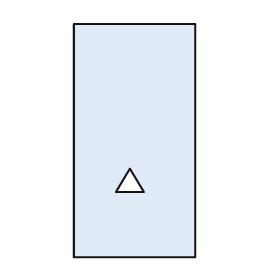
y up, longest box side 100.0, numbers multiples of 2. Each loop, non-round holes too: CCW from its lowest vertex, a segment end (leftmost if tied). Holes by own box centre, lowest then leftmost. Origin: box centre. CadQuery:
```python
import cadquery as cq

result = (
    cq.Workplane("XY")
    .moveTo(-26.0, -50.0)
    .lineTo(26.0, -50.0)
    .lineTo(26.0, 50.0)
    .lineTo(-26.0, 50.0)
    .close()
    .moveTo(-8.0, -22.0)
    .lineTo(4.0, -22.0)
    .lineTo(-2.0, -12.0)
    .close()
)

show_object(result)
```